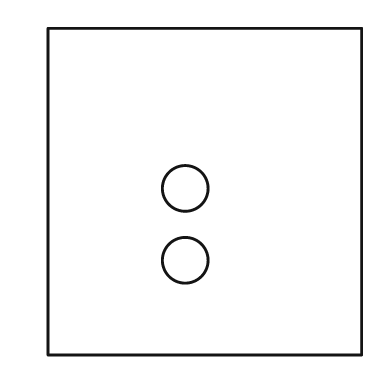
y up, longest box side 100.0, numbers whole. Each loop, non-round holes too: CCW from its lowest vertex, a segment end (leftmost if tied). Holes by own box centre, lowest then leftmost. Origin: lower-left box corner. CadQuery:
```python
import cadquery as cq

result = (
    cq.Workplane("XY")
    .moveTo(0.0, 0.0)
    .lineTo(96.0, 0.0)
    .lineTo(96.0, 100.0)
    .lineTo(0.0, 100.0)
    .close()
    .moveTo(42.0, 29.0)
    .circle(7.0)
    .moveTo(42.0, 51.0)
    .circle(7.0)
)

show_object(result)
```